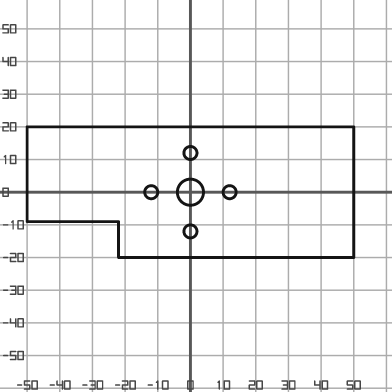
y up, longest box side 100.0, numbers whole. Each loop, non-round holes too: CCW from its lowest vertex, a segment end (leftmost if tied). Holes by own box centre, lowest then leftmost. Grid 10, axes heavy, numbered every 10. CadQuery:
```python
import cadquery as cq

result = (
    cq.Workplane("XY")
    .moveTo(-22.0, -20.0)
    .lineTo(50.0, -20.0)
    .lineTo(50.0, 20.0)
    .lineTo(-50.0, 20.0)
    .lineTo(-50.0, -9.0)
    .lineTo(-22.0, -9.0)
    .close()
    .moveTo(0.0, -12.0)
    .circle(2.0)
    .moveTo(-12.0, 0.0)
    .circle(2.0)
    .moveTo(0.0, 0.0)
    .circle(4.0)
    .moveTo(12.0, 0.0)
    .circle(2.0)
    .moveTo(0.0, 12.0)
    .circle(2.0)
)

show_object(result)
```